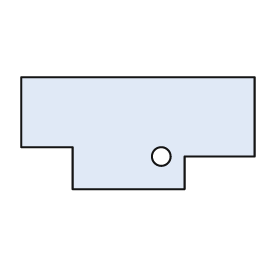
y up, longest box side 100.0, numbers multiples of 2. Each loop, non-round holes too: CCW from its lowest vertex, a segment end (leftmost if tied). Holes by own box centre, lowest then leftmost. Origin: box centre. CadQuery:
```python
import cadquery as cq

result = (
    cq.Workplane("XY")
    .moveTo(-28.0, -24.0)
    .lineTo(20.0, -24.0)
    .lineTo(20.0, -10.0)
    .lineTo(50.0, -10.0)
    .lineTo(50.0, 24.0)
    .lineTo(-50.0, 24.0)
    .lineTo(-50.0, -6.0)
    .lineTo(-28.0, -6.0)
    .close()
    .moveTo(10.0, -10.0)
    .circle(4.0)
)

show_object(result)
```